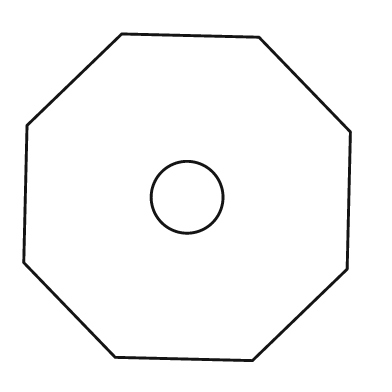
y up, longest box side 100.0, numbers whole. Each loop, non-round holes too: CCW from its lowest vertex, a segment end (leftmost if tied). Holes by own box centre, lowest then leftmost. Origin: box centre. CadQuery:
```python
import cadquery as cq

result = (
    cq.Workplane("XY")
    .moveTo(20.0, -50.0)
    .lineTo(49.0, -22.0)
    .lineTo(50.0, 20.0)
    .lineTo(22.0, 49.0)
    .lineTo(-20.0, 50.0)
    .lineTo(-49.0, 22.0)
    .lineTo(-50.0, -20.0)
    .lineTo(-22.0, -49.0)
    .close()
    .moveTo(0.0, 0.0)
    .circle(11.0)
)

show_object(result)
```